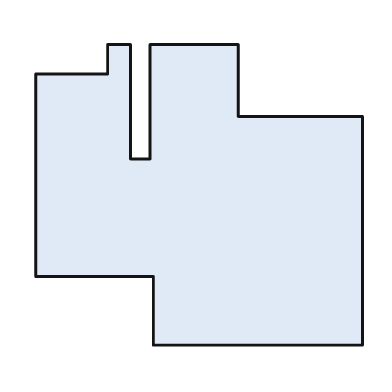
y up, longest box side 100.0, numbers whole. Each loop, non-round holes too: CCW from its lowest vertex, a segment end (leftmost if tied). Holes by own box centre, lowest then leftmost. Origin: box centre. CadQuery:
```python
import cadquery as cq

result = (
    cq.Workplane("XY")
    .moveTo(-14.0, -46.0)
    .lineTo(50.0, -46.0)
    .lineTo(50.0, 24.0)
    .lineTo(12.0, 24.0)
    .lineTo(12.0, 46.0)
    .lineTo(-15.0, 46.0)
    .lineTo(-15.0, 11.0)
    .lineTo(-21.0, 11.0)
    .lineTo(-21.0, 46.0)
    .lineTo(-28.0, 46.0)
    .lineTo(-28.0, 37.0)
    .lineTo(-50.0, 37.0)
    .lineTo(-50.0, -25.0)
    .lineTo(-14.0, -25.0)
    .close()
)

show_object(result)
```